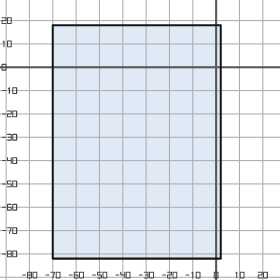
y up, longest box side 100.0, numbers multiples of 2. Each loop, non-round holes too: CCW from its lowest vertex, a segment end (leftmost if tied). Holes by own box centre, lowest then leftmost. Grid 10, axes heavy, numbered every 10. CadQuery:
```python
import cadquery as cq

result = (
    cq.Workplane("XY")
    .moveTo(-70.0, -82.0)
    .lineTo(2.0, -82.0)
    .lineTo(2.0, 18.0)
    .lineTo(-70.0, 18.0)
    .close()
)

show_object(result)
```